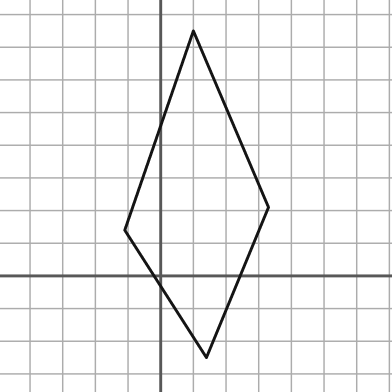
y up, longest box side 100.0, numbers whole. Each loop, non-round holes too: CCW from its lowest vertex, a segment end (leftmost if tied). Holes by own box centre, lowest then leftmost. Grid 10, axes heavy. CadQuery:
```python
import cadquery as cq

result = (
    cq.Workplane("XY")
    .moveTo(14.0, -25.0)
    .lineTo(33.0, 21.0)
    .lineTo(10.0, 75.0)
    .lineTo(-11.0, 14.0)
    .close()
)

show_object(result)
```